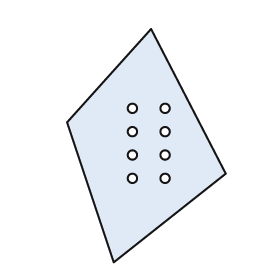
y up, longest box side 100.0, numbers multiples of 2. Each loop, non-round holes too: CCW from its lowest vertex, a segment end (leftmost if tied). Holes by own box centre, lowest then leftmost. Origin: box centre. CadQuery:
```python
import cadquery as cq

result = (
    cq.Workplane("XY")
    .moveTo(-14.0, -50.0)
    .lineTo(34.0, -12.0)
    .lineTo(2.0, 50.0)
    .lineTo(-34.0, 10.0)
    .close()
    .moveTo(-6.0, -14.0)
    .circle(2.0)
    .moveTo(8.0, -14.0)
    .circle(2.0)
    .moveTo(-6.0, -4.0)
    .circle(2.0)
    .moveTo(8.0, -4.0)
    .circle(2.0)
    .moveTo(-6.0, 6.0)
    .circle(2.0)
    .moveTo(8.0, 6.0)
    .circle(2.0)
    .moveTo(-6.0, 16.0)
    .circle(2.0)
    .moveTo(8.0, 16.0)
    .circle(2.0)
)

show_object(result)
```